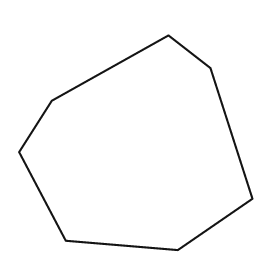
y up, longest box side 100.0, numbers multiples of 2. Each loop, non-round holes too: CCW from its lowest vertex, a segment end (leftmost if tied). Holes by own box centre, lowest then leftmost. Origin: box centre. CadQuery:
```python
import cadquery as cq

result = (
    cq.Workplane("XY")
    .moveTo(18.0, -46.0)
    .lineTo(50.0, -24.0)
    .lineTo(32.0, 32.0)
    .lineTo(14.0, 46.0)
    .lineTo(-36.0, 18.0)
    .lineTo(-50.0, -4.0)
    .lineTo(-30.0, -42.0)
    .close()
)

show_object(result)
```